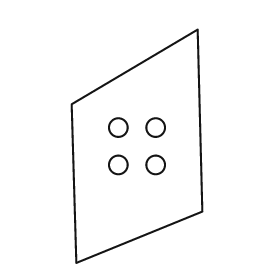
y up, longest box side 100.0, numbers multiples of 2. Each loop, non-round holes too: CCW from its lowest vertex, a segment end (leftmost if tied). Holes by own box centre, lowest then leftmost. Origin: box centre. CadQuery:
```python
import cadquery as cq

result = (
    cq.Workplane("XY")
    .moveTo(-26.0, -50.0)
    .lineTo(28.0, -28.0)
    .lineTo(26.0, 50.0)
    .lineTo(-28.0, 18.0)
    .close()
    .moveTo(-8.0, -8.0)
    .circle(4.0)
    .moveTo(8.0, -8.0)
    .circle(4.0)
    .moveTo(-8.0, 8.0)
    .circle(4.0)
    .moveTo(8.0, 8.0)
    .circle(4.0)
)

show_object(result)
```